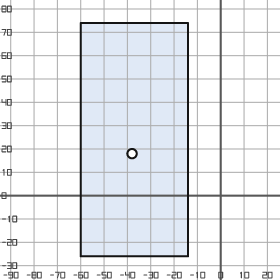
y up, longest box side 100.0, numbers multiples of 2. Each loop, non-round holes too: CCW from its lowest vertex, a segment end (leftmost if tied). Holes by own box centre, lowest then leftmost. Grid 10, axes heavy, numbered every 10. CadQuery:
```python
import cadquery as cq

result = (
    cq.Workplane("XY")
    .moveTo(-60.0, -26.0)
    .lineTo(-14.0, -26.0)
    .lineTo(-14.0, 74.0)
    .lineTo(-60.0, 74.0)
    .close()
    .moveTo(-38.0, 18.0)
    .circle(2.0)
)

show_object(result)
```